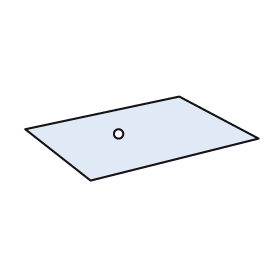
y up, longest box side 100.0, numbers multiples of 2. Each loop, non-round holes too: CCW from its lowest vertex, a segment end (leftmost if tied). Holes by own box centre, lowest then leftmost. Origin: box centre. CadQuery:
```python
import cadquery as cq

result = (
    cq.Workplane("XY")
    .moveTo(-22.0, -18.0)
    .lineTo(50.0, 0.0)
    .lineTo(16.0, 18.0)
    .lineTo(-50.0, 4.0)
    .close()
    .moveTo(-10.0, 2.0)
    .circle(2.0)
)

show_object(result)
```